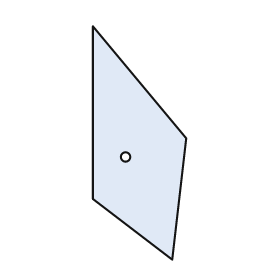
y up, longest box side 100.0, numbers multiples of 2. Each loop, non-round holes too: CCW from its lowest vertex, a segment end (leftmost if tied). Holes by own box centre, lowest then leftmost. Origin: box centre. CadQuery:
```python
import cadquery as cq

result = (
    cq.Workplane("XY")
    .moveTo(14.0, -50.0)
    .lineTo(20.0, 2.0)
    .lineTo(-20.0, 50.0)
    .lineTo(-20.0, -24.0)
    .close()
    .moveTo(-6.0, -6.0)
    .circle(2.0)
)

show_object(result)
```